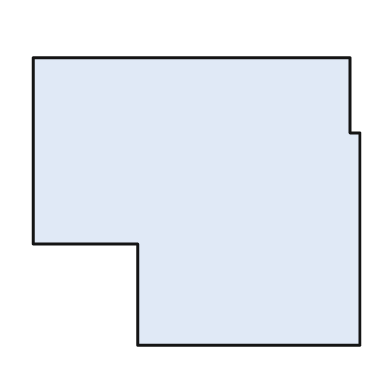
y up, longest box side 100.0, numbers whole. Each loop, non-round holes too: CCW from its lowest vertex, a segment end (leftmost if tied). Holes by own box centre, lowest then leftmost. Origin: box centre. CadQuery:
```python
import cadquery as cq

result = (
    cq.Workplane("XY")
    .moveTo(-18.0, -44.0)
    .lineTo(50.0, -44.0)
    .lineTo(50.0, 21.0)
    .lineTo(47.0, 21.0)
    .lineTo(47.0, 44.0)
    .lineTo(-50.0, 44.0)
    .lineTo(-50.0, -13.0)
    .lineTo(-18.0, -13.0)
    .close()
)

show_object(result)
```